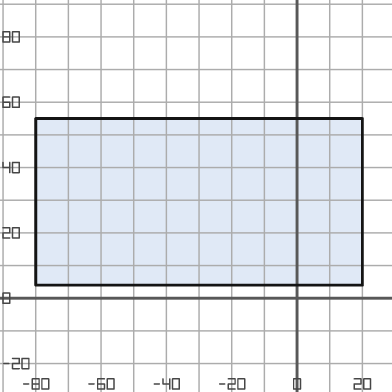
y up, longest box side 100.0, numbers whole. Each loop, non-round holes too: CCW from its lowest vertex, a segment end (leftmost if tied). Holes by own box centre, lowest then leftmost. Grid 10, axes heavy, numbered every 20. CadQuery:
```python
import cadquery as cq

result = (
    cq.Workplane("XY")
    .moveTo(-80.0, 4.0)
    .lineTo(20.0, 4.0)
    .lineTo(20.0, 55.0)
    .lineTo(-80.0, 55.0)
    .close()
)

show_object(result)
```